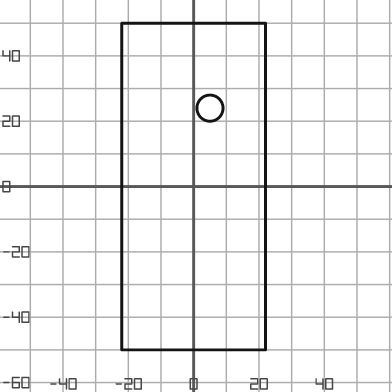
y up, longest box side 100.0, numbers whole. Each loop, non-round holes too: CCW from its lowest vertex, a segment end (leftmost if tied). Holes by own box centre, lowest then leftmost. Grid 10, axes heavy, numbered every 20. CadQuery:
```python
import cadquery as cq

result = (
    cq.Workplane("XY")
    .moveTo(-22.0, -50.0)
    .lineTo(22.0, -50.0)
    .lineTo(22.0, 50.0)
    .lineTo(-22.0, 50.0)
    .close()
    .moveTo(5.0, 24.0)
    .circle(4.0)
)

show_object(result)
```